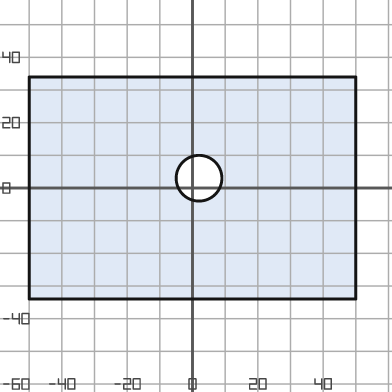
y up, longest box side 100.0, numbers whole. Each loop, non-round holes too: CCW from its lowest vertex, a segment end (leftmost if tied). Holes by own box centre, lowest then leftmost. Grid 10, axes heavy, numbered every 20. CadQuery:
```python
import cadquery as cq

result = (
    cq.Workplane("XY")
    .moveTo(-50.0, -34.0)
    .lineTo(50.0, -34.0)
    .lineTo(50.0, 34.0)
    .lineTo(-50.0, 34.0)
    .close()
    .moveTo(2.0, 3.0)
    .circle(7.0)
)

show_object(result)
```